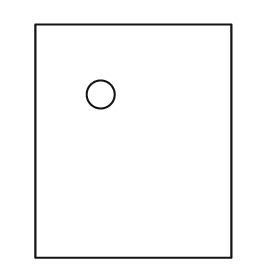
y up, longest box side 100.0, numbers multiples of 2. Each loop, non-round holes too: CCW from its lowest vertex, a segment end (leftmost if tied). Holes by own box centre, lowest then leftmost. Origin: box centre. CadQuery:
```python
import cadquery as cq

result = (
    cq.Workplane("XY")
    .moveTo(-42.0, -50.0)
    .lineTo(42.0, -50.0)
    .lineTo(42.0, 50.0)
    .lineTo(-42.0, 50.0)
    .close()
    .moveTo(-14.0, 20.0)
    .circle(6.0)
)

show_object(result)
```